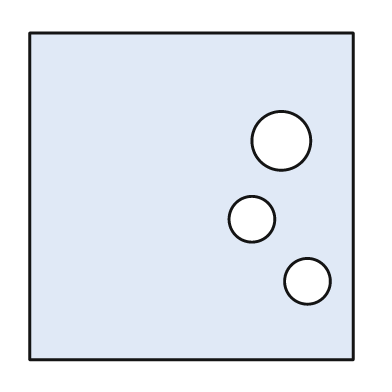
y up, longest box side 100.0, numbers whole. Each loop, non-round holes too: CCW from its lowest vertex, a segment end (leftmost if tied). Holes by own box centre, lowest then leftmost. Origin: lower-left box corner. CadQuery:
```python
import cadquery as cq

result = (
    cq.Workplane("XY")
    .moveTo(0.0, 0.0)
    .lineTo(99.0, 0.0)
    .lineTo(99.0, 100.0)
    .lineTo(0.0, 100.0)
    .close()
    .moveTo(85.0, 24.0)
    .circle(7.0)
    .moveTo(68.0, 43.0)
    .circle(7.0)
    .moveTo(77.0, 67.0)
    .circle(9.0)
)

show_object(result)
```